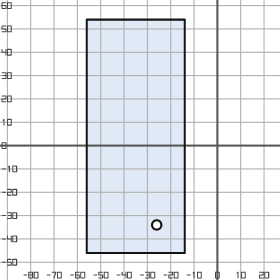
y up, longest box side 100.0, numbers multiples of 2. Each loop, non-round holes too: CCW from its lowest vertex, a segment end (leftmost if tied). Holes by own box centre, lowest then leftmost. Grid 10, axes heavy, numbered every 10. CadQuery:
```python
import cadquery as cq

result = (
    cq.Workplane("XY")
    .moveTo(-56.0, -46.0)
    .lineTo(-14.0, -46.0)
    .lineTo(-14.0, 54.0)
    .lineTo(-56.0, 54.0)
    .close()
    .moveTo(-26.0, -34.0)
    .circle(2.0)
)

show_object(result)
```